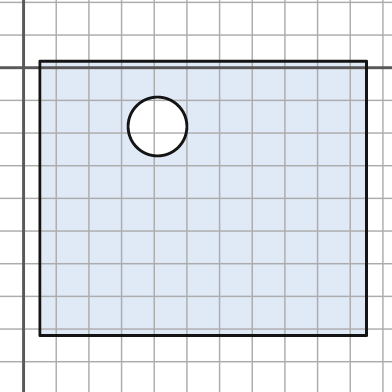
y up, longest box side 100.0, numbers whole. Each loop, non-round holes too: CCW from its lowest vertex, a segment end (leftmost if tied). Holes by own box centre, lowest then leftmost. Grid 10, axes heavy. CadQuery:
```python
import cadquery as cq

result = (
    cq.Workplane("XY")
    .moveTo(5.0, -82.0)
    .lineTo(105.0, -82.0)
    .lineTo(105.0, 2.0)
    .lineTo(5.0, 2.0)
    .close()
    .moveTo(41.0, -18.0)
    .circle(9.0)
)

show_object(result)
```